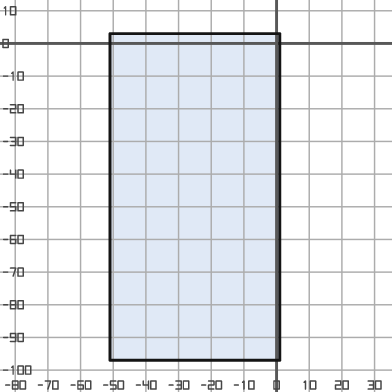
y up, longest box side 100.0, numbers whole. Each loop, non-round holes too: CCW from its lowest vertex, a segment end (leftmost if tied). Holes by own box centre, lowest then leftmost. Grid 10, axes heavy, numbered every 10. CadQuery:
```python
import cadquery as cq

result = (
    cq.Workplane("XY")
    .moveTo(-51.0, -97.0)
    .lineTo(1.0, -97.0)
    .lineTo(1.0, 3.0)
    .lineTo(-51.0, 3.0)
    .close()
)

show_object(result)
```